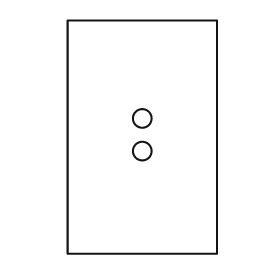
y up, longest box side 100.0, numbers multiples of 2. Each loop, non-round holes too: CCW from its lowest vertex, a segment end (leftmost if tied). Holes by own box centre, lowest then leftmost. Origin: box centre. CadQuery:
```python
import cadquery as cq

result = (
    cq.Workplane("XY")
    .moveTo(-32.0, -50.0)
    .lineTo(32.0, -50.0)
    .lineTo(32.0, 50.0)
    .lineTo(-32.0, 50.0)
    .close()
    .moveTo(0.0, -6.0)
    .circle(4.0)
    .moveTo(0.0, 8.0)
    .circle(4.0)
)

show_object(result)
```